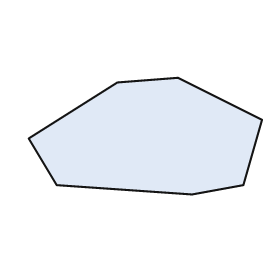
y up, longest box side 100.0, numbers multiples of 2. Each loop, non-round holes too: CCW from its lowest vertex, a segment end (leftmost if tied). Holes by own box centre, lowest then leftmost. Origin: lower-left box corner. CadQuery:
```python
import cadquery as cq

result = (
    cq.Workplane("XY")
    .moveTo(70.0, 0.0)
    .lineTo(92.0, 4.0)
    .lineTo(100.0, 32.0)
    .lineTo(64.0, 50.0)
    .lineTo(38.0, 48.0)
    .lineTo(0.0, 24.0)
    .lineTo(12.0, 4.0)
    .close()
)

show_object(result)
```